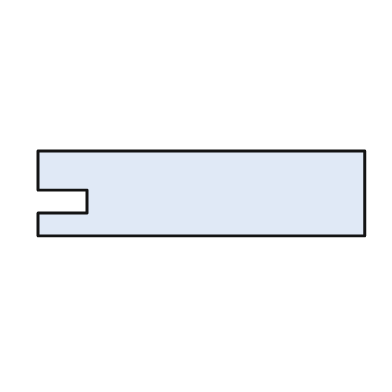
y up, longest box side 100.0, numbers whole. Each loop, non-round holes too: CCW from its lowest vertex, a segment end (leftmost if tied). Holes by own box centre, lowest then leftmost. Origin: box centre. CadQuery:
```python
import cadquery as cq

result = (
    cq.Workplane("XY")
    .moveTo(-50.0, -13.0)
    .lineTo(50.0, -13.0)
    .lineTo(50.0, 13.0)
    .lineTo(-50.0, 13.0)
    .lineTo(-50.0, 1.0)
    .lineTo(-35.0, 1.0)
    .lineTo(-35.0, -6.0)
    .lineTo(-50.0, -6.0)
    .close()
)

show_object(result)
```